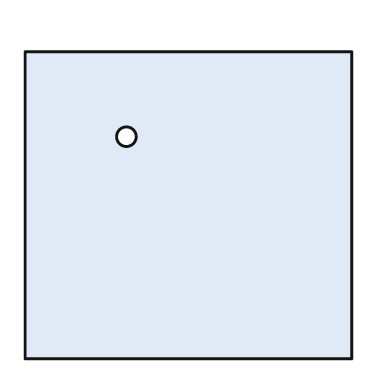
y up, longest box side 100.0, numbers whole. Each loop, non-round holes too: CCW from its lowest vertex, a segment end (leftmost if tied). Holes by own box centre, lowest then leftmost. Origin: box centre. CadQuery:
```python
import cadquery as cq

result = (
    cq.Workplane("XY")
    .moveTo(-50.0, -47.0)
    .lineTo(50.0, -47.0)
    .lineTo(50.0, 47.0)
    .lineTo(-50.0, 47.0)
    .close()
    .moveTo(-19.0, 21.0)
    .circle(3.0)
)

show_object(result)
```